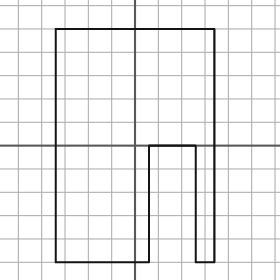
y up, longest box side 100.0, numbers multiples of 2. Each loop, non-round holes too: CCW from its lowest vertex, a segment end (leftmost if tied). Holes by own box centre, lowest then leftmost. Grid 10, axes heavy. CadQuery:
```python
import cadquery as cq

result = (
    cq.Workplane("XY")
    .moveTo(-34.0, -50.0)
    .lineTo(6.0, -50.0)
    .lineTo(6.0, 0.0)
    .lineTo(26.0, 0.0)
    .lineTo(26.0, -50.0)
    .lineTo(34.0, -50.0)
    .lineTo(34.0, 50.0)
    .lineTo(-34.0, 50.0)
    .close()
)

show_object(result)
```